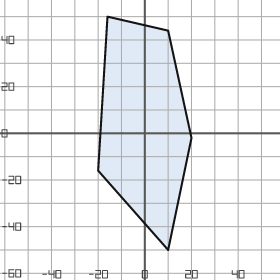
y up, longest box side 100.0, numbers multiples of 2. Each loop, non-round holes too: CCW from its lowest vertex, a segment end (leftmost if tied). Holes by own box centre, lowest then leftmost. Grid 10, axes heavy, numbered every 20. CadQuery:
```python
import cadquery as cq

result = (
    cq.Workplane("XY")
    .moveTo(10.0, -50.0)
    .lineTo(20.0, -2.0)
    .lineTo(10.0, 44.0)
    .lineTo(-16.0, 50.0)
    .lineTo(-20.0, -16.0)
    .close()
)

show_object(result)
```